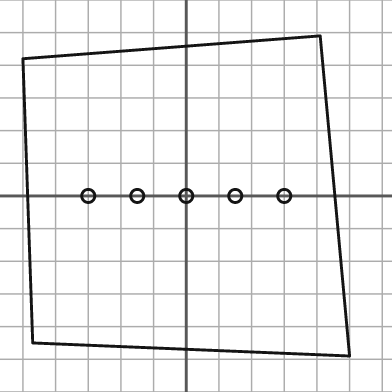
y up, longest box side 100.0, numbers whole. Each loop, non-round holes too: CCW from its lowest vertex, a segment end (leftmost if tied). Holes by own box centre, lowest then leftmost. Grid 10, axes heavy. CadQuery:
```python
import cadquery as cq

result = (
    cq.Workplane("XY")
    .moveTo(50.0, -49.0)
    .lineTo(41.0, 49.0)
    .lineTo(-50.0, 42.0)
    .lineTo(-47.0, -45.0)
    .close()
    .moveTo(-30.0, 0.0)
    .circle(2.0)
    .moveTo(-15.0, 0.0)
    .circle(2.0)
    .moveTo(0.0, 0.0)
    .circle(2.0)
    .moveTo(15.0, 0.0)
    .circle(2.0)
    .moveTo(30.0, 0.0)
    .circle(2.0)
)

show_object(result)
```